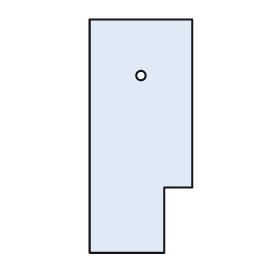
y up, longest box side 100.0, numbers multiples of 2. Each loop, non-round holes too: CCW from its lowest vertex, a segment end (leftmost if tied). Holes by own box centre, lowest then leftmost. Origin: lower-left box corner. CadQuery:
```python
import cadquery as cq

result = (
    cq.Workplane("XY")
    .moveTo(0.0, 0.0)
    .lineTo(32.0, 0.0)
    .lineTo(32.0, 28.0)
    .lineTo(44.0, 28.0)
    .lineTo(44.0, 100.0)
    .lineTo(0.0, 100.0)
    .close()
    .moveTo(22.0, 76.0)
    .circle(2.0)
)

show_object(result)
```